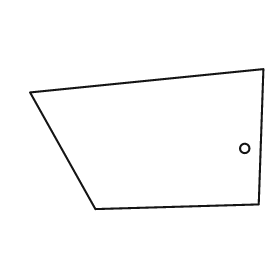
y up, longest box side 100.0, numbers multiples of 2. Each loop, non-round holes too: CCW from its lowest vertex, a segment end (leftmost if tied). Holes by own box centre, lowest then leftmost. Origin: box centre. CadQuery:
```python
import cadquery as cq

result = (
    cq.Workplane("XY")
    .moveTo(-22.0, -30.0)
    .lineTo(48.0, -28.0)
    .lineTo(50.0, 30.0)
    .lineTo(-50.0, 20.0)
    .close()
    .moveTo(42.0, -4.0)
    .circle(2.0)
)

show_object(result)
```